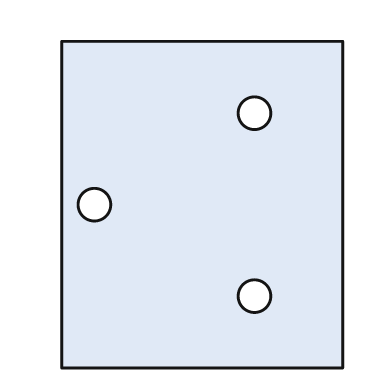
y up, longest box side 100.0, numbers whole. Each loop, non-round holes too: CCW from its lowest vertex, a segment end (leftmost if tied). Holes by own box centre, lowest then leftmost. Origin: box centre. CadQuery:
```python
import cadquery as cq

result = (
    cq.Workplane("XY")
    .moveTo(-43.0, -50.0)
    .lineTo(43.0, -50.0)
    .lineTo(43.0, 50.0)
    .lineTo(-43.0, 50.0)
    .close()
    .moveTo(16.0, -28.0)
    .circle(5.0)
    .moveTo(-33.0, 0.0)
    .circle(5.0)
    .moveTo(16.0, 28.0)
    .circle(5.0)
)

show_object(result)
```